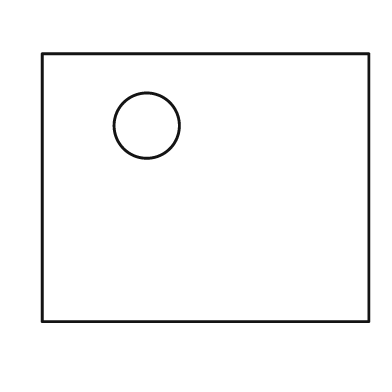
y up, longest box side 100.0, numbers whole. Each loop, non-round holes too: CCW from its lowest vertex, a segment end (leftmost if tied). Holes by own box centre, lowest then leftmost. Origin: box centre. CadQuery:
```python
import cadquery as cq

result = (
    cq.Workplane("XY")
    .moveTo(-50.0, -41.0)
    .lineTo(50.0, -41.0)
    .lineTo(50.0, 41.0)
    .lineTo(-50.0, 41.0)
    .close()
    .moveTo(-18.0, 19.0)
    .circle(10.0)
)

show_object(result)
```